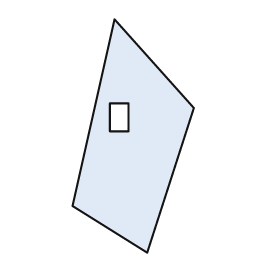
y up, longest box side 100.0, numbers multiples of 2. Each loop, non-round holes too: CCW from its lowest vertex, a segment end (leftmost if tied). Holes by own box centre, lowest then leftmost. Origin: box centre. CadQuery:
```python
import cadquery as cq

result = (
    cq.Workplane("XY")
    .moveTo(6.0, -50.0)
    .lineTo(26.0, 12.0)
    .lineTo(-8.0, 50.0)
    .lineTo(-26.0, -30.0)
    .close()
    .moveTo(-10.0, 2.0)
    .lineTo(-2.0, 2.0)
    .lineTo(-2.0, 14.0)
    .lineTo(-10.0, 14.0)
    .close()
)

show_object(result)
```